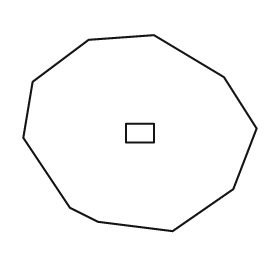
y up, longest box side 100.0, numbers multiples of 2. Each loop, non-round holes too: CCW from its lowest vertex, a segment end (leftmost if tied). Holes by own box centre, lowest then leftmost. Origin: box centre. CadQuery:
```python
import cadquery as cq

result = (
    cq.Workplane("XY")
    .moveTo(14.0, -42.0)
    .lineTo(40.0, -24.0)
    .lineTo(50.0, 2.0)
    .lineTo(36.0, 24.0)
    .lineTo(6.0, 42.0)
    .lineTo(-22.0, 40.0)
    .lineTo(-46.0, 22.0)
    .lineTo(-50.0, -2.0)
    .lineTo(-30.0, -32.0)
    .lineTo(-18.0, -38.0)
    .close()
    .moveTo(-6.0, -4.0)
    .lineTo(6.0, -4.0)
    .lineTo(6.0, 4.0)
    .lineTo(-6.0, 4.0)
    .close()
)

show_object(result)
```